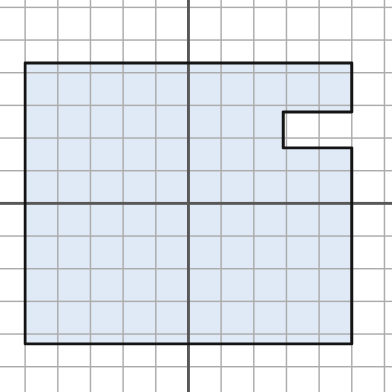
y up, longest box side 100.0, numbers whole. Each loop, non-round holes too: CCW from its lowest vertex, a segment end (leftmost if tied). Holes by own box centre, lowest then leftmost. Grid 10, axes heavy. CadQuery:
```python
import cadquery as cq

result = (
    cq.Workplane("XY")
    .moveTo(-50.0, -43.0)
    .lineTo(50.0, -43.0)
    .lineTo(50.0, 17.0)
    .lineTo(29.0, 17.0)
    .lineTo(29.0, 28.0)
    .lineTo(50.0, 28.0)
    .lineTo(50.0, 43.0)
    .lineTo(-50.0, 43.0)
    .close()
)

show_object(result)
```